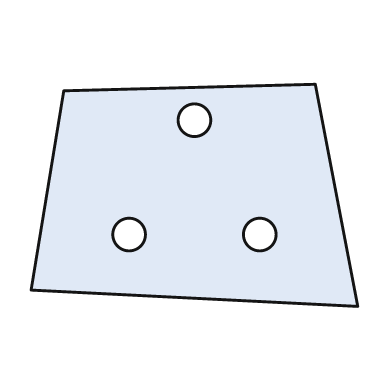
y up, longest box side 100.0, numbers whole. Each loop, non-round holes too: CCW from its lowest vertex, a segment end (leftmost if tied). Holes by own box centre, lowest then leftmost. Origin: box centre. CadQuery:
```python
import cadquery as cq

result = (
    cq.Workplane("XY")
    .moveTo(50.0, -34.0)
    .lineTo(37.0, 34.0)
    .lineTo(-40.0, 32.0)
    .lineTo(-50.0, -29.0)
    .close()
    .moveTo(-20.0, -12.0)
    .circle(5.0)
    .moveTo(20.0, -12.0)
    .circle(5.0)
    .moveTo(0.0, 23.0)
    .circle(5.0)
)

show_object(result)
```